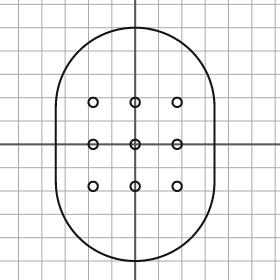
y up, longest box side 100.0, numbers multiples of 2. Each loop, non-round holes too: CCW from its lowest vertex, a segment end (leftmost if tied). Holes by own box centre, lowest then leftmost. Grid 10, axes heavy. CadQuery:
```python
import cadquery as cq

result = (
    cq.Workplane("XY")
    .moveTo(-34.0, -16.0)
    .threePointArc((0.0, -50.0), (34.0, -16.0))
    .lineTo(34.0, 16.0)
    .threePointArc((0.0, 50.0), (-34.0, 16.0))
    .close()
    .moveTo(-18.0, -18.0)
    .circle(2.0)
    .moveTo(0.0, -18.0)
    .circle(2.0)
    .moveTo(18.0, -18.0)
    .circle(2.0)
    .moveTo(-18.0, 0.0)
    .circle(2.0)
    .moveTo(0.0, 0.0)
    .circle(2.0)
    .moveTo(18.0, 0.0)
    .circle(2.0)
    .moveTo(-18.0, 18.0)
    .circle(2.0)
    .moveTo(0.0, 18.0)
    .circle(2.0)
    .moveTo(18.0, 18.0)
    .circle(2.0)
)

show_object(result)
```